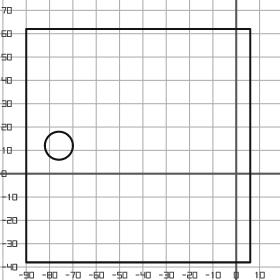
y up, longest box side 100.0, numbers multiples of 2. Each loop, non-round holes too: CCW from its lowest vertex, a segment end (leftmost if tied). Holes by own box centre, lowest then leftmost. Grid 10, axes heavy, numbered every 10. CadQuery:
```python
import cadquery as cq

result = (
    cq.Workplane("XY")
    .moveTo(-90.0, -38.0)
    .lineTo(6.0, -38.0)
    .lineTo(6.0, 62.0)
    .lineTo(-90.0, 62.0)
    .close()
    .moveTo(-76.0, 12.0)
    .circle(6.0)
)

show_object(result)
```